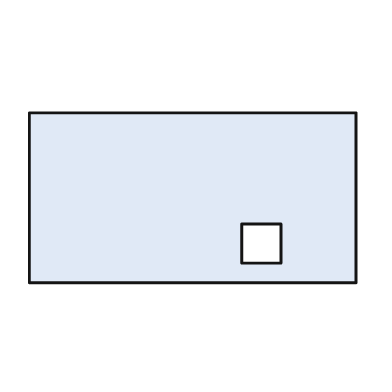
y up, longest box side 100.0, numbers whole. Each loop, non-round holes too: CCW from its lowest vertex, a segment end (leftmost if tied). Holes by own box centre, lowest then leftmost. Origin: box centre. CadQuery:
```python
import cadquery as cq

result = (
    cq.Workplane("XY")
    .moveTo(-50.0, -26.0)
    .lineTo(50.0, -26.0)
    .lineTo(50.0, 26.0)
    .lineTo(-50.0, 26.0)
    .close()
    .moveTo(15.0, -20.0)
    .lineTo(27.0, -20.0)
    .lineTo(27.0, -8.0)
    .lineTo(15.0, -8.0)
    .close()
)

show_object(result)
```